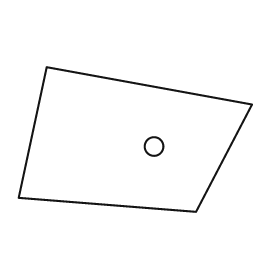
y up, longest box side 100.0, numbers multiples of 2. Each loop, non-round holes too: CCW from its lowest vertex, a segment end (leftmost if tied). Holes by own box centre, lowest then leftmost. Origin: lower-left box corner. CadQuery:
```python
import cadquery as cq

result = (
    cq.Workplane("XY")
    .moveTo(76.0, 0.0)
    .lineTo(100.0, 46.0)
    .lineTo(12.0, 62.0)
    .lineTo(0.0, 6.0)
    .close()
    .moveTo(58.0, 28.0)
    .circle(4.0)
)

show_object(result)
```